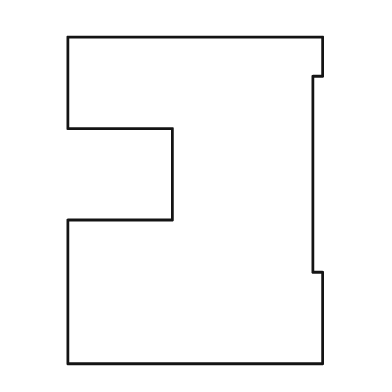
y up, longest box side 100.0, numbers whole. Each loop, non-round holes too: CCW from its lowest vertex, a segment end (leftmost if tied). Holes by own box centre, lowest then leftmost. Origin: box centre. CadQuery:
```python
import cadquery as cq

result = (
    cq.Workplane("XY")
    .moveTo(-39.0, -50.0)
    .lineTo(39.0, -50.0)
    .lineTo(39.0, -22.0)
    .lineTo(36.0, -22.0)
    .lineTo(36.0, 38.0)
    .lineTo(39.0, 38.0)
    .lineTo(39.0, 50.0)
    .lineTo(-39.0, 50.0)
    .lineTo(-39.0, 22.0)
    .lineTo(-7.0, 22.0)
    .lineTo(-7.0, -6.0)
    .lineTo(-39.0, -6.0)
    .close()
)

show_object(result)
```